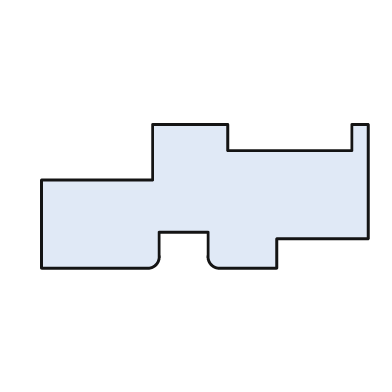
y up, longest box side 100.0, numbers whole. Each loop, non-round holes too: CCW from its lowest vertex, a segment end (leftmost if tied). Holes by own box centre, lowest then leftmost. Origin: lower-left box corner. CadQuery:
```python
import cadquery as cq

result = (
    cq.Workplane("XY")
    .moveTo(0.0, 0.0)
    .lineTo(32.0, 0.0)
    .threePointArc((35.0, 1.0), (36.0, 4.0))
    .lineTo(36.0, 11.0)
    .lineTo(51.0, 11.0)
    .lineTo(51.0, 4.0)
    .threePointArc((52.0, 1.0), (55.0, 0.0))
    .lineTo(72.0, 0.0)
    .lineTo(72.0, 9.0)
    .lineTo(100.0, 9.0)
    .lineTo(100.0, 44.0)
    .lineTo(95.0, 44.0)
    .lineTo(95.0, 36.0)
    .lineTo(57.0, 36.0)
    .lineTo(57.0, 44.0)
    .lineTo(34.0, 44.0)
    .lineTo(34.0, 27.0)
    .lineTo(0.0, 27.0)
    .close()
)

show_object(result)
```